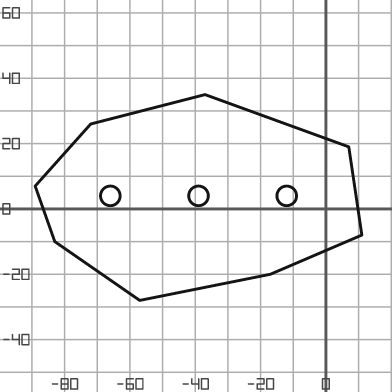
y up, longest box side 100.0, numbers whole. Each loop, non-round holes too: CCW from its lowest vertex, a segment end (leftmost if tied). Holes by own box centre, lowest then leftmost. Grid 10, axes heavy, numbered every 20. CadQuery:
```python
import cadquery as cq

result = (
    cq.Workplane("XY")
    .moveTo(-57.0, -28.0)
    .lineTo(-17.0, -20.0)
    .lineTo(11.0, -8.0)
    .lineTo(7.0, 19.0)
    .lineTo(-37.0, 35.0)
    .lineTo(-72.0, 26.0)
    .lineTo(-89.0, 7.0)
    .lineTo(-83.0, -10.0)
    .close()
    .moveTo(-66.0, 4.0)
    .circle(3.0)
    .moveTo(-39.0, 4.0)
    .circle(3.0)
    .moveTo(-12.0, 4.0)
    .circle(3.0)
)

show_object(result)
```